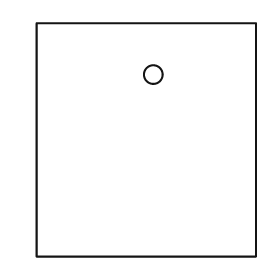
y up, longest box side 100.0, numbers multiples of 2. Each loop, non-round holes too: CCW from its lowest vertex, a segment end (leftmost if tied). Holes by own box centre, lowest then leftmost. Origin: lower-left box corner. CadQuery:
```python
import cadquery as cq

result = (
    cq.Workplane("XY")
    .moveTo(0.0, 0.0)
    .lineTo(94.0, 0.0)
    .lineTo(94.0, 100.0)
    .lineTo(0.0, 100.0)
    .close()
    .moveTo(50.0, 78.0)
    .circle(4.0)
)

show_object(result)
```